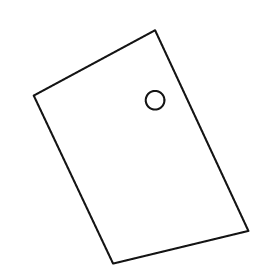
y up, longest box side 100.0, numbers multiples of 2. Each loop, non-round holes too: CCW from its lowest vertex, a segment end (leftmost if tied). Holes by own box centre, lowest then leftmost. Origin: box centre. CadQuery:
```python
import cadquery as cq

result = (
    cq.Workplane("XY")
    .moveTo(-12.0, -50.0)
    .lineTo(46.0, -36.0)
    .lineTo(6.0, 50.0)
    .lineTo(-46.0, 22.0)
    .close()
    .moveTo(6.0, 20.0)
    .circle(4.0)
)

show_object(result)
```